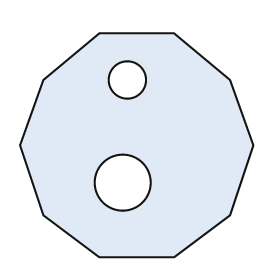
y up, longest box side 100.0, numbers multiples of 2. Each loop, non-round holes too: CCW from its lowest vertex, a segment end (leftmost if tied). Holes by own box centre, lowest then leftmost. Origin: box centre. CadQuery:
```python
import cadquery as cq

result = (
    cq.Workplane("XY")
    .moveTo(-16.0, -48.0)
    .lineTo(16.0, -48.0)
    .lineTo(40.0, -30.0)
    .lineTo(50.0, 0.0)
    .lineTo(40.0, 28.0)
    .lineTo(16.0, 48.0)
    .lineTo(-16.0, 48.0)
    .lineTo(-40.0, 28.0)
    .lineTo(-50.0, 0.0)
    .lineTo(-40.0, -30.0)
    .close()
    .moveTo(-6.0, -16.0)
    .circle(12.0)
    .moveTo(-4.0, 28.0)
    .circle(8.0)
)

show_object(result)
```